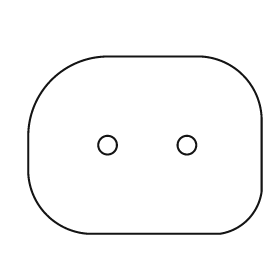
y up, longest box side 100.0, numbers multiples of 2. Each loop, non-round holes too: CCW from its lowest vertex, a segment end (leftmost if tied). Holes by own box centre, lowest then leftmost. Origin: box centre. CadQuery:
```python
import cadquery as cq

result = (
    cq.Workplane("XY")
    .moveTo(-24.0, -38.0)
    .lineTo(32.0, -38.0)
    .threePointArc((44.0, -32.0), (50.0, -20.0))
    .lineTo(50.0, 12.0)
    .threePointArc((42.0, 30.0), (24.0, 38.0))
    .lineTo(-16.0, 38.0)
    .threePointArc((-40.0, 28.0), (-50.0, 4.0))
    .lineTo(-50.0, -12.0)
    .threePointArc((-42.0, -30.0), (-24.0, -38.0))
    .close()
    .moveTo(-16.0, 0.0)
    .circle(4.0)
    .moveTo(18.0, 0.0)
    .circle(4.0)
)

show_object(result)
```